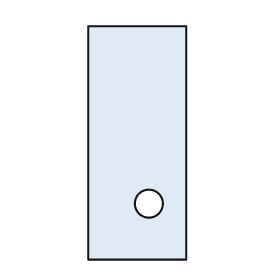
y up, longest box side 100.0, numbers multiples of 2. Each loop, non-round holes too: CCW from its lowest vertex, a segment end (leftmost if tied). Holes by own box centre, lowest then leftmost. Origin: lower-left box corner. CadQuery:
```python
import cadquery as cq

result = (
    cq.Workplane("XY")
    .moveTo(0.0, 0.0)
    .lineTo(42.0, 0.0)
    .lineTo(42.0, 100.0)
    .lineTo(0.0, 100.0)
    .close()
    .moveTo(26.0, 24.0)
    .circle(6.0)
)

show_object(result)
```